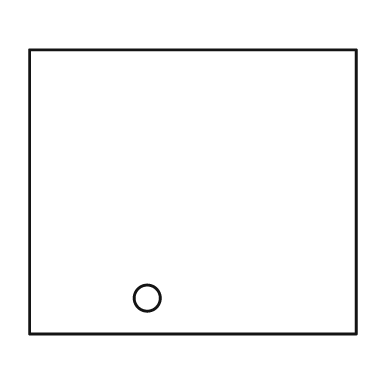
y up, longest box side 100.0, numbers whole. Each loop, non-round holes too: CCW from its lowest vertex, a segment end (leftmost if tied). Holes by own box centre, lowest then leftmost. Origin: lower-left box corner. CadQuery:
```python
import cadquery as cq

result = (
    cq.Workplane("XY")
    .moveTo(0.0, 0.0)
    .lineTo(100.0, 0.0)
    .lineTo(100.0, 87.0)
    .lineTo(0.0, 87.0)
    .close()
    .moveTo(36.0, 11.0)
    .circle(4.0)
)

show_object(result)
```